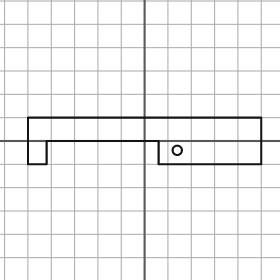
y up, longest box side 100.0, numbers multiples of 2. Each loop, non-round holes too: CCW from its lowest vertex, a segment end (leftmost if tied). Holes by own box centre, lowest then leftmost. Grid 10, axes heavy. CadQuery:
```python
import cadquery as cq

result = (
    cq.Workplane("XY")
    .moveTo(-50.0, -10.0)
    .lineTo(-42.0, -10.0)
    .lineTo(-42.0, 0.0)
    .lineTo(6.0, 0.0)
    .lineTo(6.0, -10.0)
    .lineTo(50.0, -10.0)
    .lineTo(50.0, 10.0)
    .lineTo(-50.0, 10.0)
    .close()
    .moveTo(14.0, -4.0)
    .circle(2.0)
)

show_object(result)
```